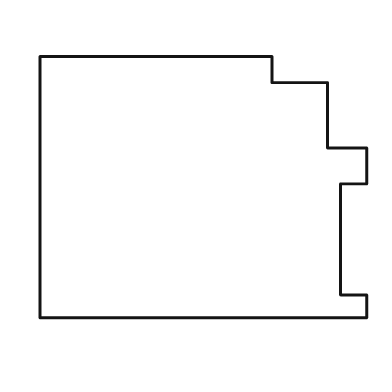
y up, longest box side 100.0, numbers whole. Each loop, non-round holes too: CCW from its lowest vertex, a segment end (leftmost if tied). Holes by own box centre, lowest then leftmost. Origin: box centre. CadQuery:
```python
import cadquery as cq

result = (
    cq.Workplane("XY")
    .moveTo(-50.0, -40.0)
    .lineTo(50.0, -40.0)
    .lineTo(50.0, -33.0)
    .lineTo(42.0, -33.0)
    .lineTo(42.0, 1.0)
    .lineTo(50.0, 1.0)
    .lineTo(50.0, 12.0)
    .lineTo(38.0, 12.0)
    .lineTo(38.0, 32.0)
    .lineTo(21.0, 32.0)
    .lineTo(21.0, 40.0)
    .lineTo(-50.0, 40.0)
    .close()
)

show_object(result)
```